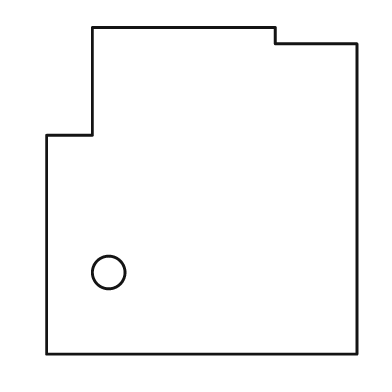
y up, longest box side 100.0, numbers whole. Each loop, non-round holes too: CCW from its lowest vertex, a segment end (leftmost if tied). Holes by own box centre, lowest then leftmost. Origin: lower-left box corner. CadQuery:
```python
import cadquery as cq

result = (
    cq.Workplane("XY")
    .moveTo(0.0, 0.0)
    .lineTo(95.0, 0.0)
    .lineTo(95.0, 95.0)
    .lineTo(70.0, 95.0)
    .lineTo(70.0, 100.0)
    .lineTo(14.0, 100.0)
    .lineTo(14.0, 67.0)
    .lineTo(0.0, 67.0)
    .close()
    .moveTo(19.0, 25.0)
    .circle(5.0)
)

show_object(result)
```